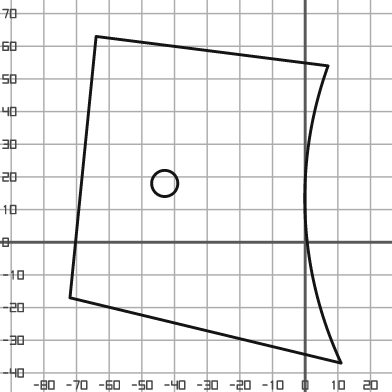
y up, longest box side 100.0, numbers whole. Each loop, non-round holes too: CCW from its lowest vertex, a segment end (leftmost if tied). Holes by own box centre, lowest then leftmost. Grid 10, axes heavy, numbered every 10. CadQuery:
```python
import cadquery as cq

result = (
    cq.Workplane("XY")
    .moveTo(11.0, -37.0)
    .threePointArc((0.0, 8.0), (7.0, 54.0))
    .lineTo(-64.0, 63.0)
    .lineTo(-72.0, -17.0)
    .close()
    .moveTo(-43.0, 18.0)
    .circle(4.0)
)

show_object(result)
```